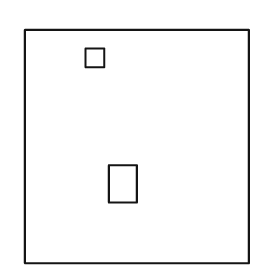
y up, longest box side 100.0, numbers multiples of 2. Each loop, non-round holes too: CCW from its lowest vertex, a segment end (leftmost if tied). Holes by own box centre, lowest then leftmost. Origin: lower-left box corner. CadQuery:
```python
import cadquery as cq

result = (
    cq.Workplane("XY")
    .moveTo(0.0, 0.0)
    .lineTo(96.0, 0.0)
    .lineTo(96.0, 100.0)
    .lineTo(0.0, 100.0)
    .close()
    .moveTo(36.0, 26.0)
    .lineTo(48.0, 26.0)
    .lineTo(48.0, 42.0)
    .lineTo(36.0, 42.0)
    .close()
    .moveTo(26.0, 84.0)
    .lineTo(34.0, 84.0)
    .lineTo(34.0, 92.0)
    .lineTo(26.0, 92.0)
    .close()
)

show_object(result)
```